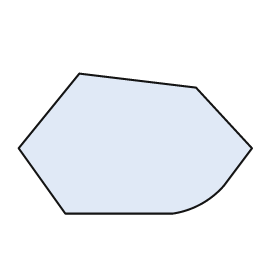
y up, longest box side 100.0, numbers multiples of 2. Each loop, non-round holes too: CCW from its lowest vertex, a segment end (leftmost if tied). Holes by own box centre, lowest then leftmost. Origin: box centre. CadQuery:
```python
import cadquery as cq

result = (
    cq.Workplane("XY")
    .moveTo(-30.0, -30.0)
    .lineTo(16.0, -30.0)
    .threePointArc((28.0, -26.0), (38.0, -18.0))
    .lineTo(50.0, -2.0)
    .lineTo(26.0, 24.0)
    .lineTo(-24.0, 30.0)
    .lineTo(-50.0, -2.0)
    .close()
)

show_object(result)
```